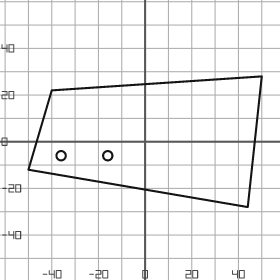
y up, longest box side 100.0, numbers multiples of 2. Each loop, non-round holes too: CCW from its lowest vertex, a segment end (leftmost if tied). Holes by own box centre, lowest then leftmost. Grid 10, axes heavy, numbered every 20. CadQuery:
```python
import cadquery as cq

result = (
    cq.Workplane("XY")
    .moveTo(44.0, -28.0)
    .lineTo(50.0, 28.0)
    .lineTo(-40.0, 22.0)
    .lineTo(-50.0, -12.0)
    .close()
    .moveTo(-36.0, -6.0)
    .circle(2.0)
    .moveTo(-16.0, -6.0)
    .circle(2.0)
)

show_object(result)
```